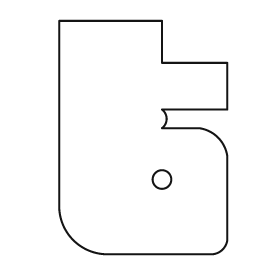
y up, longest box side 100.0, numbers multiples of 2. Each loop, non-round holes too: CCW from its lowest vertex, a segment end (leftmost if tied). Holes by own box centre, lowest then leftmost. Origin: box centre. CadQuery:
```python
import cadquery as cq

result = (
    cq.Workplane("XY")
    .moveTo(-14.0, -50.0)
    .lineTo(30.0, -50.0)
    .threePointArc((34.0, -48.0), (36.0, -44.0))
    .lineTo(36.0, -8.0)
    .threePointArc((32.0, 0.0), (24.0, 4.0))
    .lineTo(8.0, 4.0)
    .threePointArc((10.0, 8.0), (8.0, 12.0))
    .lineTo(36.0, 12.0)
    .lineTo(36.0, 32.0)
    .lineTo(8.0, 32.0)
    .lineTo(8.0, 50.0)
    .lineTo(-36.0, 50.0)
    .lineTo(-36.0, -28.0)
    .threePointArc((-30.0, -44.0), (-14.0, -50.0))
    .close()
    .moveTo(8.0, -18.0)
    .circle(4.0)
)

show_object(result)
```